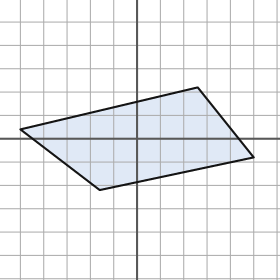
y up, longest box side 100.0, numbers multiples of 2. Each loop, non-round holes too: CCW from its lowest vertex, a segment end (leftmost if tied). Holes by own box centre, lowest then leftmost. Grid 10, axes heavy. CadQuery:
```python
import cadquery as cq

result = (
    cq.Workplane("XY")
    .moveTo(-16.0, -22.0)
    .lineTo(50.0, -8.0)
    .lineTo(26.0, 22.0)
    .lineTo(-50.0, 4.0)
    .close()
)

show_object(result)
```